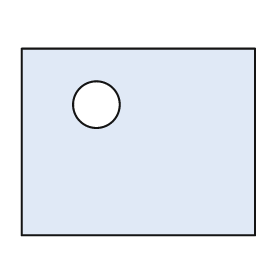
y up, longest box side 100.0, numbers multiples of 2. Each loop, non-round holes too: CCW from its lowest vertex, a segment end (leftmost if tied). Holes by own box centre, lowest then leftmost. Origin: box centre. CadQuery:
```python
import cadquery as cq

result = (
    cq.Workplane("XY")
    .moveTo(-50.0, -40.0)
    .lineTo(50.0, -40.0)
    .lineTo(50.0, 40.0)
    .lineTo(-50.0, 40.0)
    .close()
    .moveTo(-18.0, 16.0)
    .circle(10.0)
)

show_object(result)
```